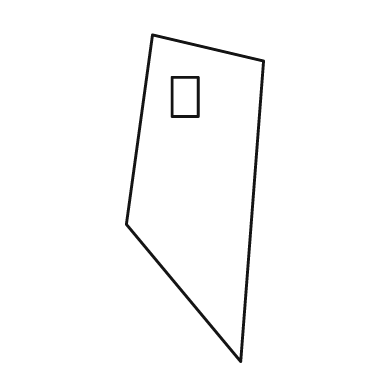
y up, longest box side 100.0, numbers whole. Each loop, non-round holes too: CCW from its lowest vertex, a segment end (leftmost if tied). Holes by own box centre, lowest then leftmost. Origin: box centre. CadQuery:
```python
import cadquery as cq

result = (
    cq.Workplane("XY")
    .moveTo(14.0, -50.0)
    .lineTo(21.0, 42.0)
    .lineTo(-13.0, 50.0)
    .lineTo(-21.0, -8.0)
    .close()
    .moveTo(-7.0, 25.0)
    .lineTo(1.0, 25.0)
    .lineTo(1.0, 37.0)
    .lineTo(-7.0, 37.0)
    .close()
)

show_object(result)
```